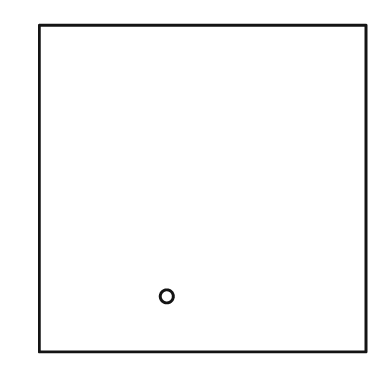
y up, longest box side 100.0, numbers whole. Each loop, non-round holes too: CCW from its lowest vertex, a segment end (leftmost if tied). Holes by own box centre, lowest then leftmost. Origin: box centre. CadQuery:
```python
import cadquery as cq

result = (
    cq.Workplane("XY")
    .moveTo(-50.0, -50.0)
    .lineTo(50.0, -50.0)
    .lineTo(50.0, 50.0)
    .lineTo(-50.0, 50.0)
    .close()
    .moveTo(-11.0, -33.0)
    .circle(2.0)
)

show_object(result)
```